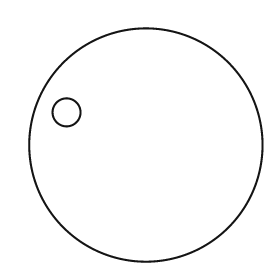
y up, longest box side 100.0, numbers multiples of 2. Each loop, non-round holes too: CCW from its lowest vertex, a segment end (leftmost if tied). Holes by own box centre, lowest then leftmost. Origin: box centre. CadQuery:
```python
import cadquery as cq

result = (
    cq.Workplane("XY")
    .moveTo(0.0, 0.0)
    .circle(50.0)
    .moveTo(-34.0, 14.0)
    .circle(6.0)
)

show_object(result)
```